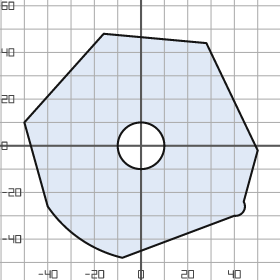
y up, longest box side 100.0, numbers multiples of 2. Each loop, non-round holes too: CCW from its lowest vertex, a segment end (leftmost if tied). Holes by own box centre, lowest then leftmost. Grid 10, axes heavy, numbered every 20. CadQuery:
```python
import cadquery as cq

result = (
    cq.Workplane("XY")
    .moveTo(-8.0, -48.0)
    .lineTo(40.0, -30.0)
    .threePointArc((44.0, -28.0), (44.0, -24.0))
    .lineTo(50.0, -2.0)
    .lineTo(28.0, 44.0)
    .lineTo(-16.0, 48.0)
    .lineTo(-50.0, 10.0)
    .lineTo(-40.0, -26.0)
    .threePointArc((-26.0, -40.0), (-8.0, -48.0))
    .close()
    .moveTo(0.0, 0.0)
    .circle(10.0)
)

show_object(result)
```